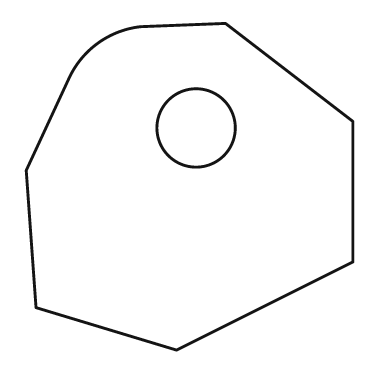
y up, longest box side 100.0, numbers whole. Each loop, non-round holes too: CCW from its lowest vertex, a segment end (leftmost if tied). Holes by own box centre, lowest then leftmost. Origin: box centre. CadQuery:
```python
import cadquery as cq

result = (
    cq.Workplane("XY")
    .moveTo(-4.0, -50.0)
    .lineTo(50.0, -23.0)
    .lineTo(50.0, 20.0)
    .lineTo(11.0, 50.0)
    .lineTo(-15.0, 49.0)
    .threePointArc((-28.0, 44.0), (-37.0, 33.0))
    .lineTo(-50.0, 5.0)
    .lineTo(-47.0, -37.0)
    .close()
    .moveTo(2.0, 18.0)
    .circle(12.0)
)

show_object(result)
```